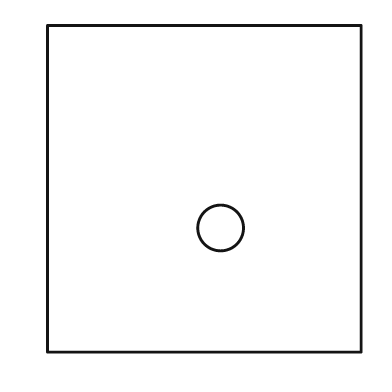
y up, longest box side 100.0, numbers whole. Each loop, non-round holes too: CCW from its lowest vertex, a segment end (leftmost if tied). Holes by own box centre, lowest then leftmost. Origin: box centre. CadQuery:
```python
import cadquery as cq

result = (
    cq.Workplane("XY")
    .moveTo(-48.0, -50.0)
    .lineTo(48.0, -50.0)
    .lineTo(48.0, 50.0)
    .lineTo(-48.0, 50.0)
    .close()
    .moveTo(5.0, -12.0)
    .circle(7.0)
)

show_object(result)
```